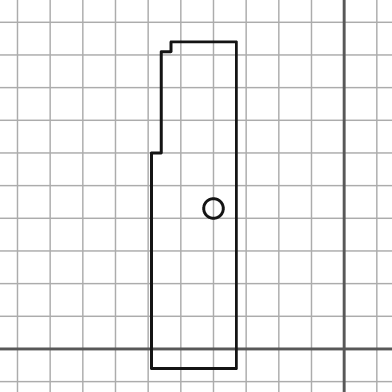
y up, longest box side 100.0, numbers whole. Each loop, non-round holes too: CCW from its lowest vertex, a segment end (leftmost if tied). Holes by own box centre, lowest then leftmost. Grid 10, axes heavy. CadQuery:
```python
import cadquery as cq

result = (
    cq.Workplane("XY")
    .moveTo(-59.0, -6.0)
    .lineTo(-33.0, -6.0)
    .lineTo(-33.0, 94.0)
    .lineTo(-53.0, 94.0)
    .lineTo(-53.0, 91.0)
    .lineTo(-56.0, 91.0)
    .lineTo(-56.0, 60.0)
    .lineTo(-59.0, 60.0)
    .close()
    .moveTo(-40.0, 43.0)
    .circle(3.0)
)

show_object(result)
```